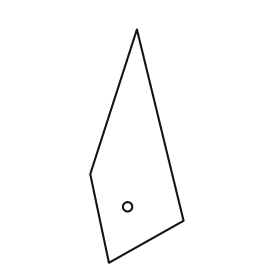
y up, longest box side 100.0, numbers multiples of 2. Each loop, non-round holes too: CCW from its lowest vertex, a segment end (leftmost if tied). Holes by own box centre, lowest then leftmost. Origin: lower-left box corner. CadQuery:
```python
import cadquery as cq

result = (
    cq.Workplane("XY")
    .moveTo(8.0, 0.0)
    .lineTo(40.0, 18.0)
    .lineTo(20.0, 100.0)
    .lineTo(0.0, 38.0)
    .close()
    .moveTo(16.0, 24.0)
    .circle(2.0)
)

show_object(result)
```